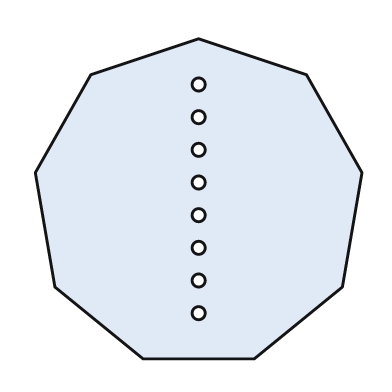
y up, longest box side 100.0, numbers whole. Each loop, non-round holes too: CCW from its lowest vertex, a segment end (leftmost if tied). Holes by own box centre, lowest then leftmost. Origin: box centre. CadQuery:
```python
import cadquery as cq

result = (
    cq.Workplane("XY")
    .moveTo(-17.0, -49.0)
    .lineTo(17.0, -49.0)
    .lineTo(44.0, -27.0)
    .lineTo(50.0, 8.0)
    .lineTo(33.0, 38.0)
    .lineTo(0.0, 49.0)
    .lineTo(-33.0, 38.0)
    .lineTo(-50.0, 8.0)
    .lineTo(-44.0, -27.0)
    .close()
    .moveTo(0.0, -35.0)
    .circle(2.0)
    .moveTo(0.0, -25.0)
    .circle(2.0)
    .moveTo(0.0, -15.0)
    .circle(2.0)
    .moveTo(0.0, -5.0)
    .circle(2.0)
    .moveTo(0.0, 5.0)
    .circle(2.0)
    .moveTo(0.0, 15.0)
    .circle(2.0)
    .moveTo(0.0, 25.0)
    .circle(2.0)
    .moveTo(0.0, 35.0)
    .circle(2.0)
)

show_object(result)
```